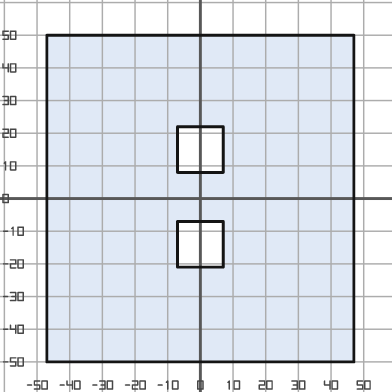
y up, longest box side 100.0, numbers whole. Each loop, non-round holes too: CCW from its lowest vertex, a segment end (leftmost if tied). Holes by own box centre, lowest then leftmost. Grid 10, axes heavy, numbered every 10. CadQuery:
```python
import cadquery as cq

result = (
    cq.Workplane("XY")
    .moveTo(-47.0, -50.0)
    .lineTo(47.0, -50.0)
    .lineTo(47.0, 50.0)
    .lineTo(-47.0, 50.0)
    .close()
    .moveTo(-7.0, -21.0)
    .lineTo(7.0, -21.0)
    .lineTo(7.0, -7.0)
    .lineTo(-7.0, -7.0)
    .close()
    .moveTo(-7.0, 8.0)
    .lineTo(7.0, 8.0)
    .lineTo(7.0, 22.0)
    .lineTo(-7.0, 22.0)
    .close()
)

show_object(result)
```